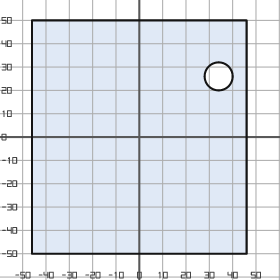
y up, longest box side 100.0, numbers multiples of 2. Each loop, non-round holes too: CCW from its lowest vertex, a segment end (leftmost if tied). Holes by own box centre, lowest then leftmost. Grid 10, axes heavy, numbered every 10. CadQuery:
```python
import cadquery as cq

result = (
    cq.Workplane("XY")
    .moveTo(-46.0, -50.0)
    .lineTo(46.0, -50.0)
    .lineTo(46.0, 50.0)
    .lineTo(-46.0, 50.0)
    .close()
    .moveTo(34.0, 26.0)
    .circle(6.0)
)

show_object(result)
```